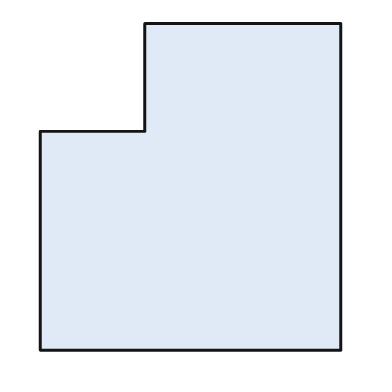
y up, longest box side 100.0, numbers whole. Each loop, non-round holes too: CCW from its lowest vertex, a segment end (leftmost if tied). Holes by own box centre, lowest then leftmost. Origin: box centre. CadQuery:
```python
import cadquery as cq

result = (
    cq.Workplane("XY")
    .moveTo(-46.0, -50.0)
    .lineTo(46.0, -50.0)
    .lineTo(46.0, 50.0)
    .lineTo(-14.0, 50.0)
    .lineTo(-14.0, 17.0)
    .lineTo(-46.0, 17.0)
    .close()
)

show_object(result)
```